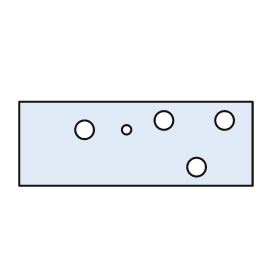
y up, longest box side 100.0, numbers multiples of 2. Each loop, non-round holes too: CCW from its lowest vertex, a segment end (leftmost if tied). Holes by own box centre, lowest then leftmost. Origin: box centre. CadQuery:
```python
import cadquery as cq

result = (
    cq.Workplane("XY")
    .moveTo(-50.0, -18.0)
    .lineTo(50.0, -18.0)
    .lineTo(50.0, 18.0)
    .lineTo(-50.0, 18.0)
    .close()
    .moveTo(26.0, -10.0)
    .circle(4.0)
    .moveTo(-22.0, 6.0)
    .circle(4.0)
    .moveTo(-4.0, 6.0)
    .circle(2.0)
    .moveTo(12.0, 10.0)
    .circle(4.0)
    .moveTo(38.0, 10.0)
    .circle(4.0)
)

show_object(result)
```